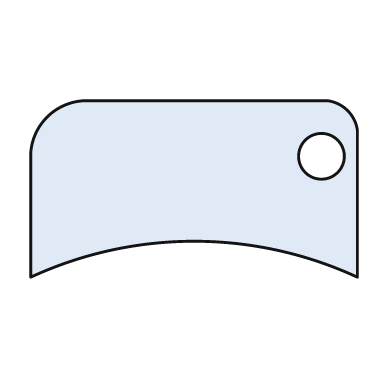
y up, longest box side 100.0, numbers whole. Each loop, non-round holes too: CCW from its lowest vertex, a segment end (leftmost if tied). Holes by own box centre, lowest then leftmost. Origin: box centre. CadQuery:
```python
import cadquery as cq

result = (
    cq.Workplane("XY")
    .moveTo(-50.0, -27.0)
    .threePointArc((0.0, -16.0), (50.0, -27.0))
    .lineTo(50.0, 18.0)
    .threePointArc((47.0, 24.0), (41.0, 27.0))
    .lineTo(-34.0, 27.0)
    .threePointArc((-45.0, 22.0), (-50.0, 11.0))
    .close()
    .moveTo(39.0, 10.0)
    .circle(7.0)
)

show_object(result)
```